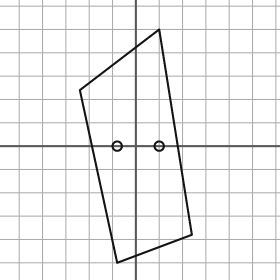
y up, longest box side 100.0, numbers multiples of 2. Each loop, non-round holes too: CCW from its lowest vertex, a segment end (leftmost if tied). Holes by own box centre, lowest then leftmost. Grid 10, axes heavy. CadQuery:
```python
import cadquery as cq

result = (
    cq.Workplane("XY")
    .moveTo(-8.0, -50.0)
    .lineTo(24.0, -38.0)
    .lineTo(10.0, 50.0)
    .lineTo(-24.0, 24.0)
    .close()
    .moveTo(-8.0, 0.0)
    .circle(2.0)
    .moveTo(10.0, 0.0)
    .circle(2.0)
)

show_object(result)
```